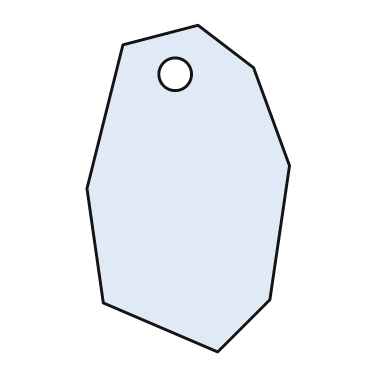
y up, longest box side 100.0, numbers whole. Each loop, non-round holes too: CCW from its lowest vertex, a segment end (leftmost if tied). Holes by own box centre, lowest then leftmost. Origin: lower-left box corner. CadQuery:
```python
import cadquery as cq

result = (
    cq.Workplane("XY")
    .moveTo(40.0, 0.0)
    .lineTo(56.0, 16.0)
    .lineTo(62.0, 57.0)
    .lineTo(51.0, 87.0)
    .lineTo(34.0, 100.0)
    .lineTo(11.0, 94.0)
    .lineTo(0.0, 50.0)
    .lineTo(5.0, 15.0)
    .close()
    .moveTo(27.0, 85.0)
    .circle(5.0)
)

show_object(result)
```